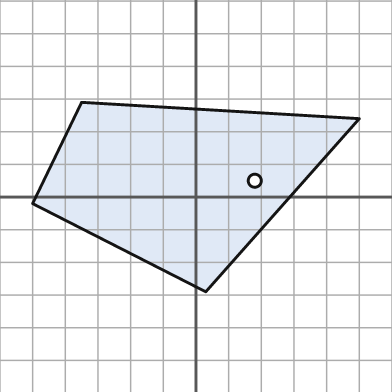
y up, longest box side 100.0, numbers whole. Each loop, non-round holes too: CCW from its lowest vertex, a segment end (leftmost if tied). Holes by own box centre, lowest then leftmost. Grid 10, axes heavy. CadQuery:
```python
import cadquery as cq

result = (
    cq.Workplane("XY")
    .moveTo(3.0, -29.0)
    .lineTo(50.0, 24.0)
    .lineTo(-35.0, 29.0)
    .lineTo(-50.0, -2.0)
    .close()
    .moveTo(18.0, 5.0)
    .circle(2.0)
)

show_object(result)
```